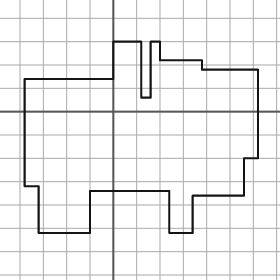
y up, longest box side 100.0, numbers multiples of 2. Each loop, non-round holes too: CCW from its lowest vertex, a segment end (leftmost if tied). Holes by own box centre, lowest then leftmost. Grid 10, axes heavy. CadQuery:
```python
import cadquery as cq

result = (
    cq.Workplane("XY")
    .moveTo(-32.0, -52.0)
    .lineTo(-10.0, -52.0)
    .lineTo(-10.0, -34.0)
    .lineTo(24.0, -34.0)
    .lineTo(24.0, -52.0)
    .lineTo(34.0, -52.0)
    .lineTo(34.0, -36.0)
    .lineTo(56.0, -36.0)
    .lineTo(56.0, -20.0)
    .lineTo(62.0, -20.0)
    .lineTo(62.0, 18.0)
    .lineTo(38.0, 18.0)
    .lineTo(38.0, 22.0)
    .lineTo(20.0, 22.0)
    .lineTo(20.0, 30.0)
    .lineTo(16.0, 30.0)
    .lineTo(16.0, 6.0)
    .lineTo(12.0, 6.0)
    .lineTo(12.0, 30.0)
    .lineTo(0.0, 30.0)
    .lineTo(0.0, 14.0)
    .lineTo(-38.0, 14.0)
    .lineTo(-38.0, -32.0)
    .lineTo(-32.0, -32.0)
    .close()
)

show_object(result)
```